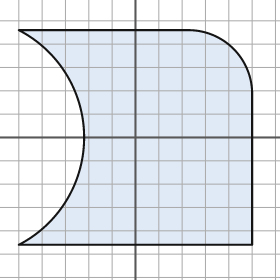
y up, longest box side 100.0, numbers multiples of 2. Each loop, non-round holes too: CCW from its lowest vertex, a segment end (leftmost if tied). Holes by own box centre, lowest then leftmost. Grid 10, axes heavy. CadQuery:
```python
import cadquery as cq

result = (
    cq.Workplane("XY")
    .moveTo(-50.0, -46.0)
    .lineTo(50.0, -46.0)
    .lineTo(50.0, 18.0)
    .threePointArc((42.0, 38.0), (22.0, 46.0))
    .lineTo(-50.0, 46.0)
    .threePointArc((-22.0, 0.0), (-50.0, -46.0))
    .close()
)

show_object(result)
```